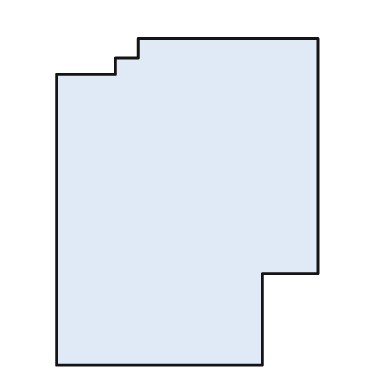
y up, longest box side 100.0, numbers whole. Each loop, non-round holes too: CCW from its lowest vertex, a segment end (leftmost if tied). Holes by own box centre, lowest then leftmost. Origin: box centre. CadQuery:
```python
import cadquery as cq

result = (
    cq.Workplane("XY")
    .moveTo(-40.0, -50.0)
    .lineTo(23.0, -50.0)
    .lineTo(23.0, -22.0)
    .lineTo(40.0, -22.0)
    .lineTo(40.0, 50.0)
    .lineTo(-15.0, 50.0)
    .lineTo(-15.0, 44.0)
    .lineTo(-22.0, 44.0)
    .lineTo(-22.0, 39.0)
    .lineTo(-40.0, 39.0)
    .close()
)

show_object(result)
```